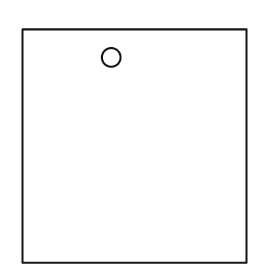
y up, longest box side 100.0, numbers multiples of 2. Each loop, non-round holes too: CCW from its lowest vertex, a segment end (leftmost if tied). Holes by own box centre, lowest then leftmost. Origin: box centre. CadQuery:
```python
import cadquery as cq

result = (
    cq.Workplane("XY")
    .moveTo(-48.0, -50.0)
    .lineTo(48.0, -50.0)
    .lineTo(48.0, 50.0)
    .lineTo(-48.0, 50.0)
    .close()
    .moveTo(-10.0, 38.0)
    .circle(4.0)
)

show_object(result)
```